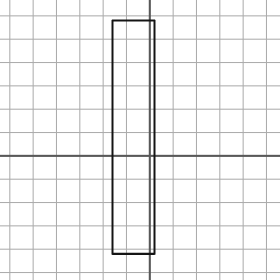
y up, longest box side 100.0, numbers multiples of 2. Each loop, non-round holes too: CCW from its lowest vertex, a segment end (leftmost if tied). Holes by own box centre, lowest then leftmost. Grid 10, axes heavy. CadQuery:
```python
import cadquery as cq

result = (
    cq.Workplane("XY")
    .moveTo(-16.0, -42.0)
    .lineTo(2.0, -42.0)
    .lineTo(2.0, 58.0)
    .lineTo(-16.0, 58.0)
    .close()
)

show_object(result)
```